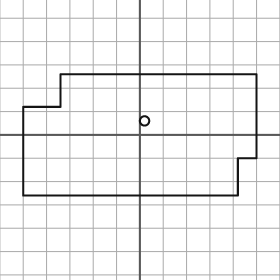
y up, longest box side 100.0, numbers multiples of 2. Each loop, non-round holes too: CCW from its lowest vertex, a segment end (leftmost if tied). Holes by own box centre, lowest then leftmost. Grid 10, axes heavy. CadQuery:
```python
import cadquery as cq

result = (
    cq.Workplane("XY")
    .moveTo(-50.0, -26.0)
    .lineTo(42.0, -26.0)
    .lineTo(42.0, -10.0)
    .lineTo(50.0, -10.0)
    .lineTo(50.0, 26.0)
    .lineTo(-34.0, 26.0)
    .lineTo(-34.0, 12.0)
    .lineTo(-50.0, 12.0)
    .close()
    .moveTo(2.0, 6.0)
    .circle(2.0)
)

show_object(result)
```